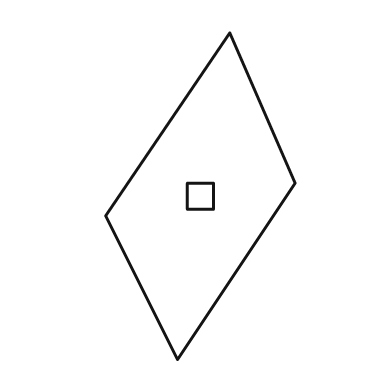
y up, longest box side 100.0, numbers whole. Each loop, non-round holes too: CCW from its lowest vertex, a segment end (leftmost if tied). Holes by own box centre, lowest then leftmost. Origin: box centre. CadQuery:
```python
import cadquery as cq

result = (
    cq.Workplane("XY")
    .moveTo(-7.0, -50.0)
    .lineTo(29.0, 4.0)
    .lineTo(9.0, 50.0)
    .lineTo(-29.0, -6.0)
    .close()
    .moveTo(-4.0, -4.0)
    .lineTo(4.0, -4.0)
    .lineTo(4.0, 4.0)
    .lineTo(-4.0, 4.0)
    .close()
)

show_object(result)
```